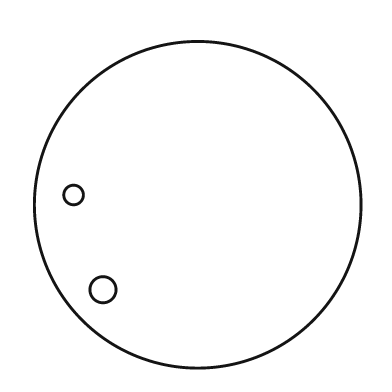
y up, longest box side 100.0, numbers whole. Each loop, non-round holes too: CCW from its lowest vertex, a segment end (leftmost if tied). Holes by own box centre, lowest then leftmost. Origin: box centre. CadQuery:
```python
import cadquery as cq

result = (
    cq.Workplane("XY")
    .moveTo(0.0, 0.0)
    .circle(50.0)
    .moveTo(-29.0, -26.0)
    .circle(4.0)
    .moveTo(-38.0, 3.0)
    .circle(3.0)
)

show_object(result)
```